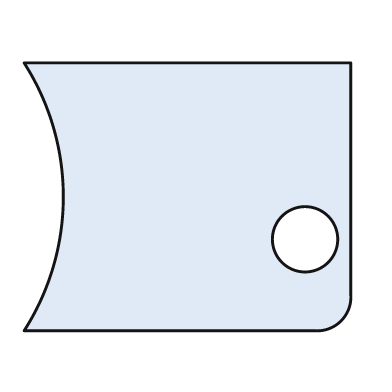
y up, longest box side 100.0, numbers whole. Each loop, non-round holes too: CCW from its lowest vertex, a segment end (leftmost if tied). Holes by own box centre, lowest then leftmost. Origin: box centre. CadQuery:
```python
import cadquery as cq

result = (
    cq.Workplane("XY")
    .moveTo(-50.0, -41.0)
    .lineTo(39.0, -41.0)
    .threePointArc((47.0, -38.0), (50.0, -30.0))
    .lineTo(50.0, 41.0)
    .lineTo(-50.0, 41.0)
    .threePointArc((-38.0, 0.0), (-50.0, -41.0))
    .close()
    .moveTo(36.0, -13.0)
    .circle(10.0)
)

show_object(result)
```